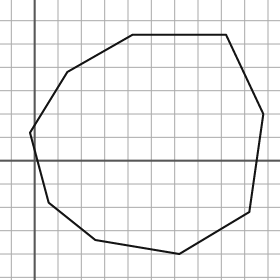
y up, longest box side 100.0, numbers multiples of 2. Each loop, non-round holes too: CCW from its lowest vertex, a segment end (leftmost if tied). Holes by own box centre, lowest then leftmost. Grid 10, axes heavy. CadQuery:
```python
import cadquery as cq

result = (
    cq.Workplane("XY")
    .moveTo(62.0, -40.0)
    .lineTo(92.0, -22.0)
    .lineTo(98.0, 20.0)
    .lineTo(82.0, 54.0)
    .lineTo(42.0, 54.0)
    .lineTo(14.0, 38.0)
    .lineTo(-2.0, 12.0)
    .lineTo(6.0, -18.0)
    .lineTo(26.0, -34.0)
    .close()
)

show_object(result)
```